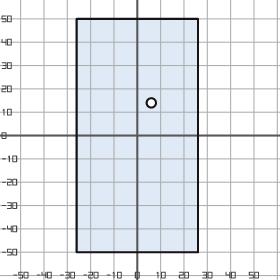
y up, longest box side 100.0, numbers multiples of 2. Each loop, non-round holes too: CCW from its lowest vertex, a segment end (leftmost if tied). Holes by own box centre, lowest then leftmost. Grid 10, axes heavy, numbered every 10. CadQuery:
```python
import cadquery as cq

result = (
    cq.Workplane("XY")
    .moveTo(-26.0, -50.0)
    .lineTo(26.0, -50.0)
    .lineTo(26.0, 50.0)
    .lineTo(-26.0, 50.0)
    .close()
    .moveTo(6.0, 14.0)
    .circle(2.0)
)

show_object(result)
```